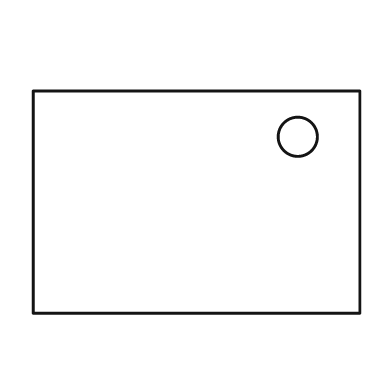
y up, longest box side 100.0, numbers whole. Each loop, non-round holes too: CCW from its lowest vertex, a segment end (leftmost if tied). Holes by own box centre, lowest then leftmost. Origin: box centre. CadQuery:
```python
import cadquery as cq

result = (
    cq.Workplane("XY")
    .moveTo(-50.0, -34.0)
    .lineTo(50.0, -34.0)
    .lineTo(50.0, 34.0)
    .lineTo(-50.0, 34.0)
    .close()
    .moveTo(31.0, 20.0)
    .circle(6.0)
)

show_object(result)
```